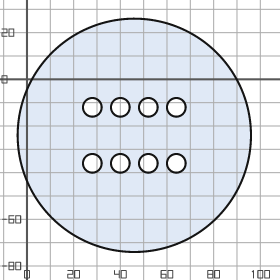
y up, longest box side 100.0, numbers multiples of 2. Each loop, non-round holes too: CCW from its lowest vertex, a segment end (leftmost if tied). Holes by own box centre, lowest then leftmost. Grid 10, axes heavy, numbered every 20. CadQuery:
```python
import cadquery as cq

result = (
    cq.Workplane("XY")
    .moveTo(46.0, -24.0)
    .circle(50.0)
    .moveTo(28.0, -36.0)
    .circle(4.0)
    .moveTo(40.0, -36.0)
    .circle(4.0)
    .moveTo(52.0, -36.0)
    .circle(4.0)
    .moveTo(64.0, -36.0)
    .circle(4.0)
    .moveTo(28.0, -12.0)
    .circle(4.0)
    .moveTo(40.0, -12.0)
    .circle(4.0)
    .moveTo(52.0, -12.0)
    .circle(4.0)
    .moveTo(64.0, -12.0)
    .circle(4.0)
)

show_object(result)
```